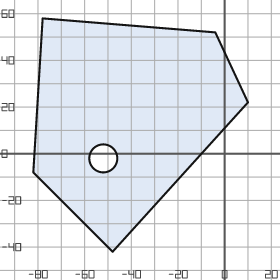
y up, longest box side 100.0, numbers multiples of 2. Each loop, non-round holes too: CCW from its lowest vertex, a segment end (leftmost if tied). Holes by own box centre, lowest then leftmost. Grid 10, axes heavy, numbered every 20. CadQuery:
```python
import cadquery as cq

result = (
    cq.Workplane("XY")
    .moveTo(-48.0, -42.0)
    .lineTo(10.0, 22.0)
    .lineTo(-4.0, 52.0)
    .lineTo(-78.0, 58.0)
    .lineTo(-82.0, -8.0)
    .close()
    .moveTo(-52.0, -2.0)
    .circle(6.0)
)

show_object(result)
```